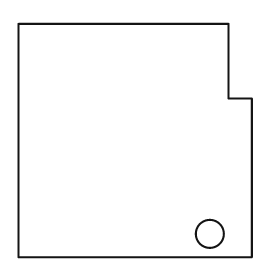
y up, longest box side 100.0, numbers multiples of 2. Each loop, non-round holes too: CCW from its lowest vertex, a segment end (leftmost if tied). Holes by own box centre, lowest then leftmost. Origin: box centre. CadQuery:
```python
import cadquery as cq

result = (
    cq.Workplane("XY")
    .moveTo(-50.0, -50.0)
    .lineTo(50.0, -50.0)
    .lineTo(50.0, 18.0)
    .lineTo(40.0, 18.0)
    .lineTo(40.0, 50.0)
    .lineTo(-50.0, 50.0)
    .close()
    .moveTo(32.0, -40.0)
    .circle(6.0)
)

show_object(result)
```